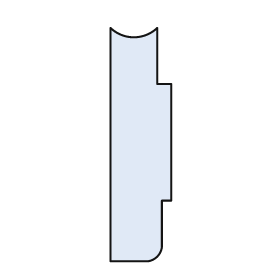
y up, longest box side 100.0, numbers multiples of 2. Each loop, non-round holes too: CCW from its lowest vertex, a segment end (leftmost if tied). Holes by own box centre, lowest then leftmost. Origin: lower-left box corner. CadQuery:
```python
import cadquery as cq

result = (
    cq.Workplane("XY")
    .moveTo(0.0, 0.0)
    .lineTo(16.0, 0.0)
    .threePointArc((20.0, 2.0), (22.0, 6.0))
    .lineTo(22.0, 26.0)
    .lineTo(26.0, 26.0)
    .lineTo(26.0, 76.0)
    .lineTo(20.0, 76.0)
    .lineTo(20.0, 100.0)
    .threePointArc((10.0, 96.0), (0.0, 100.0))
    .close()
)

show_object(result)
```